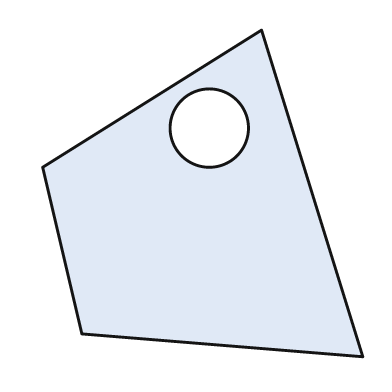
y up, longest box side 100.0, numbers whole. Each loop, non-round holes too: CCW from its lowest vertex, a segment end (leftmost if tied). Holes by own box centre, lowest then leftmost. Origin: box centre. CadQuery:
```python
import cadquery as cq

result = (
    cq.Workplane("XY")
    .moveTo(49.0, -50.0)
    .lineTo(18.0, 50.0)
    .lineTo(-49.0, 8.0)
    .lineTo(-37.0, -43.0)
    .close()
    .moveTo(2.0, 20.0)
    .circle(12.0)
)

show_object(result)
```